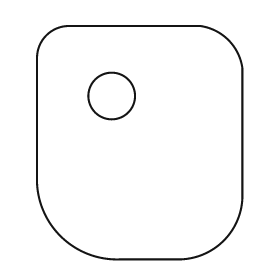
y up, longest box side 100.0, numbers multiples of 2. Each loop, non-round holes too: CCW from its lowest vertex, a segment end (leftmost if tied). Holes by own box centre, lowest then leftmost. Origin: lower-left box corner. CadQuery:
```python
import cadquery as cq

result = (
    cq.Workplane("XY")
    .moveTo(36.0, 0.0)
    .lineTo(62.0, 0.0)
    .threePointArc((80.0, 8.0), (88.0, 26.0))
    .lineTo(88.0, 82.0)
    .threePointArc((82.0, 94.0), (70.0, 100.0))
    .lineTo(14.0, 100.0)
    .threePointArc((4.0, 96.0), (0.0, 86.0))
    .lineTo(0.0, 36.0)
    .threePointArc((10.0, 10.0), (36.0, 0.0))
    .close()
    .moveTo(32.0, 70.0)
    .circle(10.0)
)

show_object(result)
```